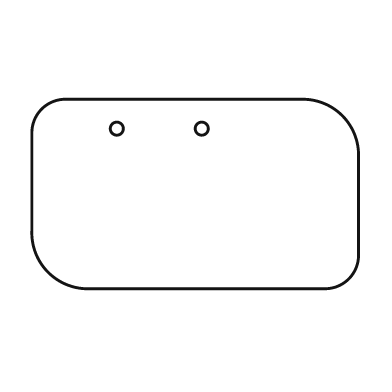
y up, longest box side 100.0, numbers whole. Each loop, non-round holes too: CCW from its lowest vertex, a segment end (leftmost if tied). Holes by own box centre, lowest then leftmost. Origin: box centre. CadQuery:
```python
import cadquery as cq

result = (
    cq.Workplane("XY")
    .moveTo(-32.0, -29.0)
    .lineTo(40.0, -29.0)
    .threePointArc((47.0, -26.0), (50.0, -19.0))
    .lineTo(50.0, 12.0)
    .threePointArc((45.0, 24.0), (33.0, 29.0))
    .lineTo(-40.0, 29.0)
    .threePointArc((-47.0, 26.0), (-50.0, 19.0))
    .lineTo(-50.0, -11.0)
    .threePointArc((-45.0, -24.0), (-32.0, -29.0))
    .close()
    .moveTo(-24.0, 20.0)
    .circle(2.0)
    .moveTo(2.0, 20.0)
    .circle(2.0)
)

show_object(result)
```